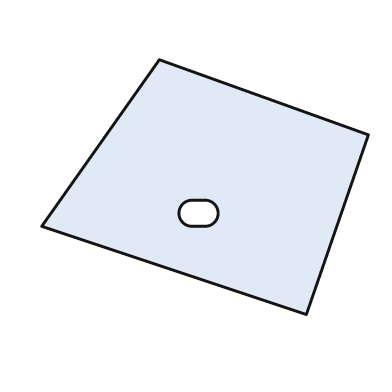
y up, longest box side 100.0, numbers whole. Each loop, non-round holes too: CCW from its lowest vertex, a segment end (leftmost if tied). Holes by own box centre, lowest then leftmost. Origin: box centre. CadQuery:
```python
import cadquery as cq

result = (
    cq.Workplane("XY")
    .moveTo(31.0, -39.0)
    .lineTo(50.0, 16.0)
    .lineTo(-14.0, 39.0)
    .lineTo(-50.0, -12.0)
    .close()
    .moveTo(-4.0, -12.0)
    .lineTo(0.0, -12.0)
    .threePointArc((4.0, -8.0), (0.0, -4.0))
    .lineTo(-4.0, -4.0)
    .threePointArc((-8.0, -8.0), (-4.0, -12.0))
    .close()
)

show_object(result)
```